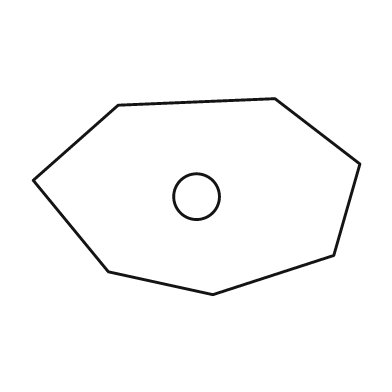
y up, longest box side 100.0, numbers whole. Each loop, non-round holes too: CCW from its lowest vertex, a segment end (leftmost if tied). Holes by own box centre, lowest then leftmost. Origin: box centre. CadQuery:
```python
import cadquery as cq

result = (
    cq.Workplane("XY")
    .moveTo(5.0, -30.0)
    .lineTo(42.0, -18.0)
    .lineTo(50.0, 10.0)
    .lineTo(24.0, 30.0)
    .lineTo(-24.0, 28.0)
    .lineTo(-50.0, 5.0)
    .lineTo(-27.0, -23.0)
    .close()
    .moveTo(0.0, 0.0)
    .circle(7.0)
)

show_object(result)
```